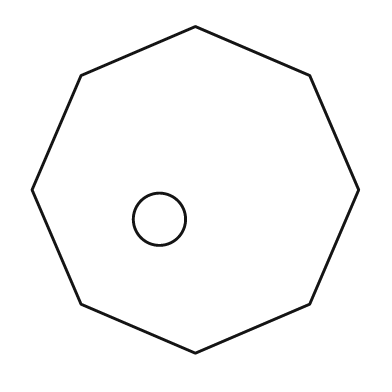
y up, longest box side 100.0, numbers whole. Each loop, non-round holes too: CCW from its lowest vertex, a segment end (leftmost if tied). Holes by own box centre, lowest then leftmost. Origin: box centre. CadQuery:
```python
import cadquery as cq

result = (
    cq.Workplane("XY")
    .moveTo(0.0, -50.0)
    .lineTo(35.0, -35.0)
    .lineTo(50.0, 0.0)
    .lineTo(35.0, 35.0)
    .lineTo(0.0, 50.0)
    .lineTo(-35.0, 35.0)
    .lineTo(-50.0, 0.0)
    .lineTo(-35.0, -35.0)
    .close()
    .moveTo(-11.0, -9.0)
    .circle(8.0)
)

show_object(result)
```